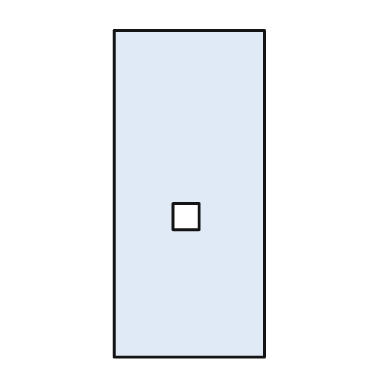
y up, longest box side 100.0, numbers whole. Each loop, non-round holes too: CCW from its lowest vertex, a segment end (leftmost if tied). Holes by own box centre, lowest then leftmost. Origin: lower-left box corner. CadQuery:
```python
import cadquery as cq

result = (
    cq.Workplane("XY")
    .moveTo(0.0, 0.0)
    .lineTo(46.0, 0.0)
    .lineTo(46.0, 100.0)
    .lineTo(0.0, 100.0)
    .close()
    .moveTo(18.0, 39.0)
    .lineTo(26.0, 39.0)
    .lineTo(26.0, 47.0)
    .lineTo(18.0, 47.0)
    .close()
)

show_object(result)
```